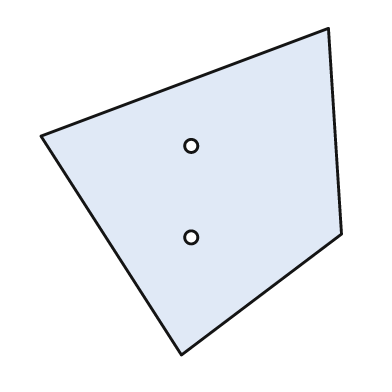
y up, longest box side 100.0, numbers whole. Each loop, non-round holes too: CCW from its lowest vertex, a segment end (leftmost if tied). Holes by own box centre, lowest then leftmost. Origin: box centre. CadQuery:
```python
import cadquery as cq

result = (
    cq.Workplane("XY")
    .moveTo(-3.0, -50.0)
    .lineTo(46.0, -13.0)
    .lineTo(42.0, 50.0)
    .lineTo(-46.0, 17.0)
    .close()
    .moveTo(0.0, -14.0)
    .circle(2.0)
    .moveTo(0.0, 14.0)
    .circle(2.0)
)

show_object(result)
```